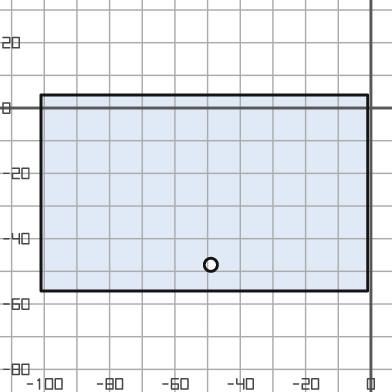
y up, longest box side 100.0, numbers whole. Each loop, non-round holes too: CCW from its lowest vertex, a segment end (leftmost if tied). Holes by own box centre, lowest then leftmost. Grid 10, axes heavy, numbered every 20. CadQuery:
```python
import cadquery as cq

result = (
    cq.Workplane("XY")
    .moveTo(-101.0, -56.0)
    .lineTo(-1.0, -56.0)
    .lineTo(-1.0, 4.0)
    .lineTo(-101.0, 4.0)
    .close()
    .moveTo(-49.0, -48.0)
    .circle(2.0)
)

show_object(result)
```